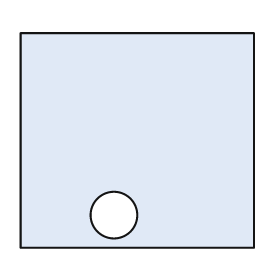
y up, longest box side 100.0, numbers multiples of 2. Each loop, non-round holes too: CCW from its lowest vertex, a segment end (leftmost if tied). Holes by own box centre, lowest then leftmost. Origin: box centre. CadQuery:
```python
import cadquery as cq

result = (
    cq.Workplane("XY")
    .moveTo(-50.0, -46.0)
    .lineTo(50.0, -46.0)
    .lineTo(50.0, 46.0)
    .lineTo(-50.0, 46.0)
    .close()
    .moveTo(-10.0, -32.0)
    .circle(10.0)
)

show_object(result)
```